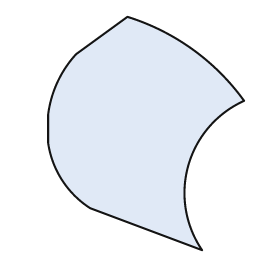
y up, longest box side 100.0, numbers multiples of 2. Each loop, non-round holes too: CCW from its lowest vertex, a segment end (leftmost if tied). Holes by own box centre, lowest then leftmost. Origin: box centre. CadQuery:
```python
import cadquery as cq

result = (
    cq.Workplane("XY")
    .moveTo(24.0, -50.0)
    .threePointArc((18.0, -14.0), (42.0, 14.0))
    .threePointArc((20.0, 36.0), (-8.0, 50.0))
    .lineTo(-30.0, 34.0)
    .threePointArc((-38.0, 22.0), (-42.0, 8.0))
    .lineTo(-42.0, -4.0)
    .threePointArc((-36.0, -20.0), (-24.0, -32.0))
    .close()
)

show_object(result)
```